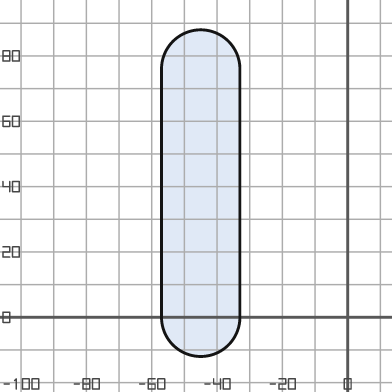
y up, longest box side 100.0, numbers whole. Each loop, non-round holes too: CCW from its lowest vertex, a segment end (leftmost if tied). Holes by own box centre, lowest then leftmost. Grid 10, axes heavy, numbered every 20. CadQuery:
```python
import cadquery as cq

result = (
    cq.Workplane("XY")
    .moveTo(-57.0, 0.0)
    .threePointArc((-45.0, -12.0), (-33.0, 0.0))
    .lineTo(-33.0, 76.0)
    .threePointArc((-45.0, 88.0), (-57.0, 76.0))
    .close()
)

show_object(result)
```